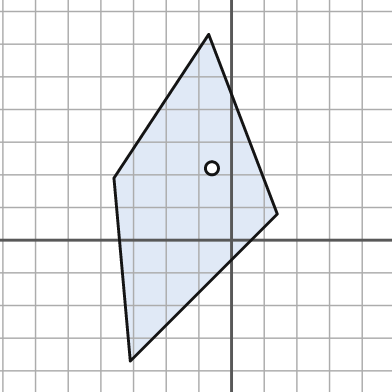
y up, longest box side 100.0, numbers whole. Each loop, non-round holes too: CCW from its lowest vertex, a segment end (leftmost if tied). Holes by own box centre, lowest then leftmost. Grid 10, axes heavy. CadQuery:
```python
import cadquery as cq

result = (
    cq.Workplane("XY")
    .moveTo(-31.0, -37.0)
    .lineTo(14.0, 8.0)
    .lineTo(-7.0, 63.0)
    .lineTo(-36.0, 19.0)
    .close()
    .moveTo(-6.0, 22.0)
    .circle(2.0)
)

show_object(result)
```